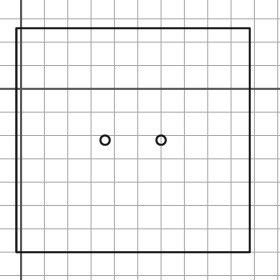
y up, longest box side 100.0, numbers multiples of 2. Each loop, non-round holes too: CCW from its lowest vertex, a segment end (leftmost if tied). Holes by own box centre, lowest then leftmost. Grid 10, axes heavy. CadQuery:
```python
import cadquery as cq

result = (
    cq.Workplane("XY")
    .moveTo(-2.0, -70.0)
    .lineTo(98.0, -70.0)
    .lineTo(98.0, 26.0)
    .lineTo(-2.0, 26.0)
    .close()
    .moveTo(36.0, -22.0)
    .circle(2.0)
    .moveTo(60.0, -22.0)
    .circle(2.0)
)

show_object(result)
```